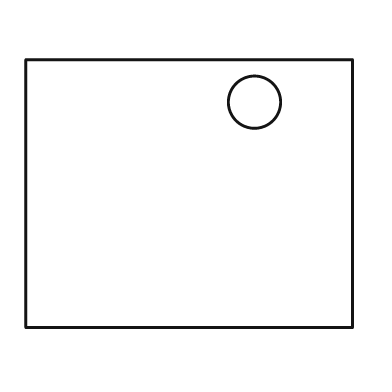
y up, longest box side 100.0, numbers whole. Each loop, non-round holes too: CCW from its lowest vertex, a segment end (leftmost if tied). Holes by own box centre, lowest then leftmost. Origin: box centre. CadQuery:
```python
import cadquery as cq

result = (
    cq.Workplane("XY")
    .moveTo(-50.0, -41.0)
    .lineTo(50.0, -41.0)
    .lineTo(50.0, 41.0)
    .lineTo(-50.0, 41.0)
    .close()
    .moveTo(20.0, 28.0)
    .circle(8.0)
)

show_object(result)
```